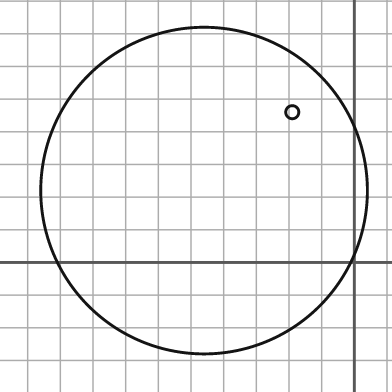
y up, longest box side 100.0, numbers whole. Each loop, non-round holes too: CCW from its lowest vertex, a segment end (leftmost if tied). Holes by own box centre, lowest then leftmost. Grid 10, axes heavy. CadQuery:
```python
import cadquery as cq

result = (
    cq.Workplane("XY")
    .moveTo(-46.0, 22.0)
    .circle(50.0)
    .moveTo(-19.0, 46.0)
    .circle(2.0)
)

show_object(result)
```